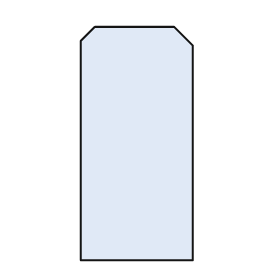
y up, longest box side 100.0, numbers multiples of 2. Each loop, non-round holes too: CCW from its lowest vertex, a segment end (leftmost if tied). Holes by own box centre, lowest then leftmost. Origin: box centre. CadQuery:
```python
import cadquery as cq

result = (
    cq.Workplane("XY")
    .moveTo(-24.0, -50.0)
    .lineTo(24.0, -50.0)
    .lineTo(24.0, 42.0)
    .lineTo(16.0, 50.0)
    .lineTo(-18.0, 50.0)
    .lineTo(-24.0, 44.0)
    .close()
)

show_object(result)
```